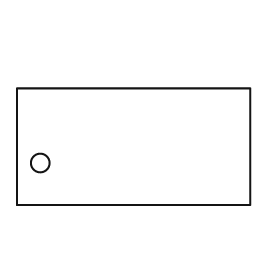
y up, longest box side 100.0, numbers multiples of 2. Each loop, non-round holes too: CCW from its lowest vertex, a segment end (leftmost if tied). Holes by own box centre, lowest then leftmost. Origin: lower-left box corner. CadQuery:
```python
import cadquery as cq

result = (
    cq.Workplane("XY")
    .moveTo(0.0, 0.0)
    .lineTo(100.0, 0.0)
    .lineTo(100.0, 50.0)
    .lineTo(0.0, 50.0)
    .close()
    .moveTo(10.0, 18.0)
    .circle(4.0)
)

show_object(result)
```